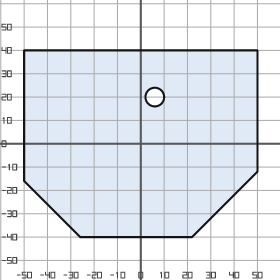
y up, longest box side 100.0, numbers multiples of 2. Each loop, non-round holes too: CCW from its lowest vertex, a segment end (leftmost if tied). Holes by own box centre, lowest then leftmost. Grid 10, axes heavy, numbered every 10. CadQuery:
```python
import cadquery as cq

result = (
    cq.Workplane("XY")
    .moveTo(-26.0, -40.0)
    .lineTo(22.0, -40.0)
    .lineTo(50.0, -12.0)
    .lineTo(50.0, 40.0)
    .lineTo(-50.0, 40.0)
    .lineTo(-50.0, -16.0)
    .close()
    .moveTo(6.0, 20.0)
    .circle(4.0)
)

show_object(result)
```